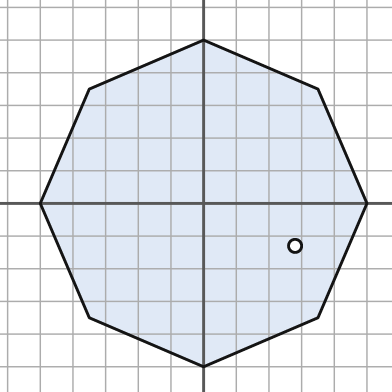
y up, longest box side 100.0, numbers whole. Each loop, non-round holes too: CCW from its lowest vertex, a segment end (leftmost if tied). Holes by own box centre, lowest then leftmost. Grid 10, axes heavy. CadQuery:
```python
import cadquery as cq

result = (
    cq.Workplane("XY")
    .moveTo(0.0, -50.0)
    .lineTo(35.0, -35.0)
    .lineTo(50.0, 0.0)
    .lineTo(35.0, 35.0)
    .lineTo(0.0, 50.0)
    .lineTo(-35.0, 35.0)
    .lineTo(-50.0, 0.0)
    .lineTo(-35.0, -35.0)
    .close()
    .moveTo(28.0, -13.0)
    .circle(2.0)
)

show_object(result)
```